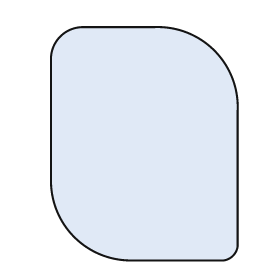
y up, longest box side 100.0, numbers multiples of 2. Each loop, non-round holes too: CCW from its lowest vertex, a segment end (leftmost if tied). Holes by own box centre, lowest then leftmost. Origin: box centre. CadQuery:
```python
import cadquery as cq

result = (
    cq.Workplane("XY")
    .moveTo(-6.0, -50.0)
    .lineTo(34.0, -50.0)
    .threePointArc((38.0, -48.0), (40.0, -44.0))
    .lineTo(40.0, 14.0)
    .threePointArc((30.0, 40.0), (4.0, 50.0))
    .lineTo(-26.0, 50.0)
    .threePointArc((-36.0, 46.0), (-40.0, 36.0))
    .lineTo(-40.0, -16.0)
    .threePointArc((-30.0, -40.0), (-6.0, -50.0))
    .close()
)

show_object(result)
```